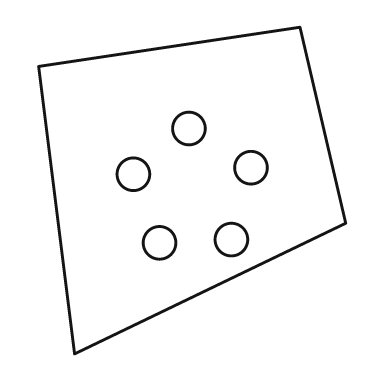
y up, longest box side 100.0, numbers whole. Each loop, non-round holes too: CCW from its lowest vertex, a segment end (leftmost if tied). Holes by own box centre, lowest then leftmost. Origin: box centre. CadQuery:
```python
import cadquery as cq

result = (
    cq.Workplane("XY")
    .moveTo(-36.0, -50.0)
    .lineTo(47.0, -10.0)
    .lineTo(33.0, 50.0)
    .lineTo(-47.0, 38.0)
    .close()
    .moveTo(-10.0, -16.0)
    .circle(5.0)
    .moveTo(12.0, -15.0)
    .circle(5.0)
    .moveTo(-18.0, 5.0)
    .circle(5.0)
    .moveTo(18.0, 7.0)
    .circle(5.0)
    .moveTo(-1.0, 19.0)
    .circle(5.0)
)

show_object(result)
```